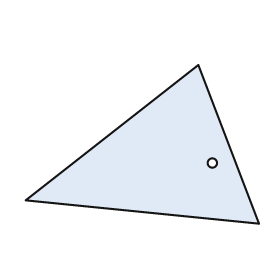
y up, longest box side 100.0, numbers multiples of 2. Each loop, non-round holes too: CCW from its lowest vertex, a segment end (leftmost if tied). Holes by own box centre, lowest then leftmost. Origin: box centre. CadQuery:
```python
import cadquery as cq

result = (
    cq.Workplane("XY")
    .moveTo(50.0, -34.0)
    .lineTo(24.0, 34.0)
    .lineTo(-50.0, -24.0)
    .close()
    .moveTo(30.0, -8.0)
    .circle(2.0)
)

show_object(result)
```